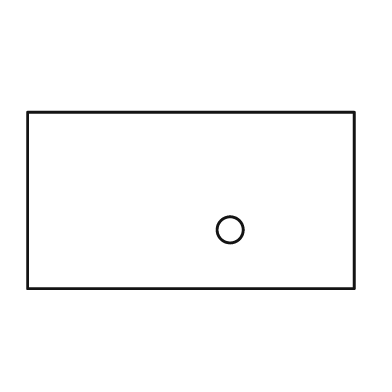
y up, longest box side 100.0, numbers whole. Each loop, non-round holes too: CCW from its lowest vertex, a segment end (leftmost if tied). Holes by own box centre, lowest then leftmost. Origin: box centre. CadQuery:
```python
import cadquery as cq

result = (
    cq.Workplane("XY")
    .moveTo(-50.0, -27.0)
    .lineTo(50.0, -27.0)
    .lineTo(50.0, 27.0)
    .lineTo(-50.0, 27.0)
    .close()
    .moveTo(12.0, -9.0)
    .circle(4.0)
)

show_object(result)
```